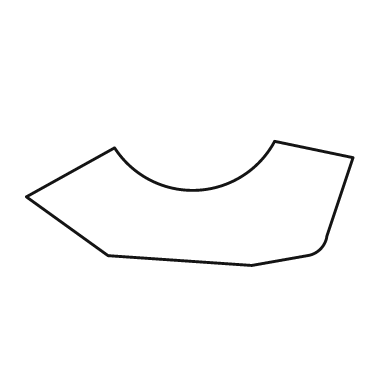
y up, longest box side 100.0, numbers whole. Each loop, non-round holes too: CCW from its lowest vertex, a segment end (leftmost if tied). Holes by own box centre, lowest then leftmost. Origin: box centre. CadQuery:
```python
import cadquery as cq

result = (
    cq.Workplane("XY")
    .moveTo(19.0, -19.0)
    .lineTo(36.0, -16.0)
    .threePointArc((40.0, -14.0), (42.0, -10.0))
    .lineTo(50.0, 14.0)
    .lineTo(26.0, 19.0)
    .threePointArc((2.0, 4.0), (-23.0, 17.0))
    .lineTo(-50.0, 2.0)
    .lineTo(-25.0, -16.0)
    .close()
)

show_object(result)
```